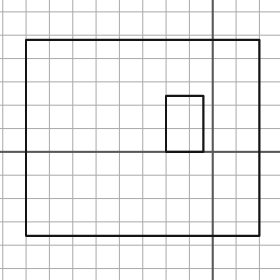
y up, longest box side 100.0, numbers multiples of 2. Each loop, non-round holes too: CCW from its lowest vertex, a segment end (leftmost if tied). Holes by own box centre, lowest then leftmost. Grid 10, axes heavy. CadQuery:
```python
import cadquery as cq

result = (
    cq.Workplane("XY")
    .moveTo(-80.0, -36.0)
    .lineTo(20.0, -36.0)
    .lineTo(20.0, 48.0)
    .lineTo(-80.0, 48.0)
    .close()
    .moveTo(-20.0, 0.0)
    .lineTo(-4.0, 0.0)
    .lineTo(-4.0, 24.0)
    .lineTo(-20.0, 24.0)
    .close()
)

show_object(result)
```